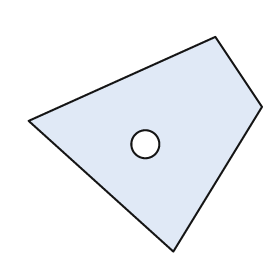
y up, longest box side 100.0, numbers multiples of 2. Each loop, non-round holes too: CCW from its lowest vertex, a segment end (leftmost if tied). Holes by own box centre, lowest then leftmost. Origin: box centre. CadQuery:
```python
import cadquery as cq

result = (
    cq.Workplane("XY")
    .moveTo(12.0, -46.0)
    .lineTo(50.0, 16.0)
    .lineTo(30.0, 46.0)
    .lineTo(-50.0, 10.0)
    .close()
    .moveTo(0.0, 0.0)
    .circle(6.0)
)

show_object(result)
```